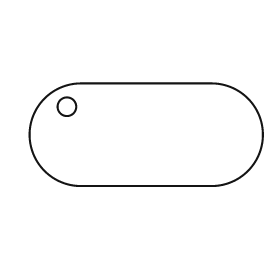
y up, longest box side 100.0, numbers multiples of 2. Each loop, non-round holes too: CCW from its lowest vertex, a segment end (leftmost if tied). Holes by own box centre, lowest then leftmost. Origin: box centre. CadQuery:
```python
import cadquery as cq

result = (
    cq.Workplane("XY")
    .moveTo(-28.0, -22.0)
    .lineTo(28.0, -22.0)
    .threePointArc((50.0, 0.0), (28.0, 22.0))
    .lineTo(-28.0, 22.0)
    .threePointArc((-50.0, 0.0), (-28.0, -22.0))
    .close()
    .moveTo(-34.0, 12.0)
    .circle(4.0)
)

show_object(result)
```